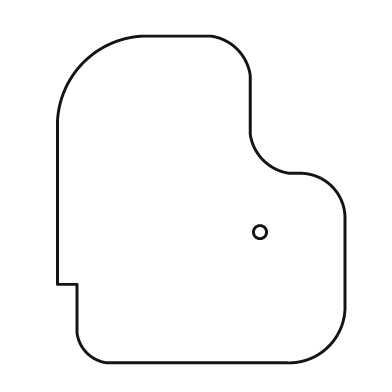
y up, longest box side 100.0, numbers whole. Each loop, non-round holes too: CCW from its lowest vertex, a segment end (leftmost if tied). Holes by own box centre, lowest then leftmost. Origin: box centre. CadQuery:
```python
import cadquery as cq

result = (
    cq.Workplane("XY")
    .moveTo(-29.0, -50.0)
    .lineTo(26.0, -50.0)
    .threePointArc((39.0, -45.0), (44.0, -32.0))
    .lineTo(44.0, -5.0)
    .threePointArc((40.0, 4.0), (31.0, 8.0))
    .lineTo(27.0, 8.0)
    .threePointArc((19.0, 12.0), (15.0, 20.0))
    .lineTo(15.0, 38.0)
    .threePointArc((11.0, 46.0), (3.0, 50.0))
    .lineTo(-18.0, 50.0)
    .threePointArc((-36.0, 42.0), (-44.0, 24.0))
    .lineTo(-44.0, -26.0)
    .lineTo(-38.0, -26.0)
    .lineTo(-38.0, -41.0)
    .threePointArc((-35.0, -47.0), (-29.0, -50.0))
    .close()
    .moveTo(18.0, -10.0)
    .circle(2.0)
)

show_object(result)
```